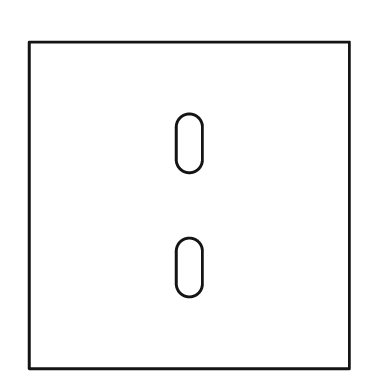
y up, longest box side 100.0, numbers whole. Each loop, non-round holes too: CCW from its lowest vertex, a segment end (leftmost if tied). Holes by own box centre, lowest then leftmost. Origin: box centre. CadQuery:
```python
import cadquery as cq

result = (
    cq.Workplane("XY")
    .moveTo(-49.0, -50.0)
    .lineTo(49.0, -50.0)
    .lineTo(49.0, 50.0)
    .lineTo(-49.0, 50.0)
    .close()
    .moveTo(-4.0, -24.0)
    .threePointArc((0.0, -28.0), (4.0, -24.0))
    .lineTo(4.0, -14.0)
    .threePointArc((0.0, -10.0), (-4.0, -14.0))
    .close()
    .moveTo(-4.0, 14.0)
    .threePointArc((0.0, 10.0), (4.0, 14.0))
    .lineTo(4.0, 24.0)
    .threePointArc((0.0, 28.0), (-4.0, 24.0))
    .close()
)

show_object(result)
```